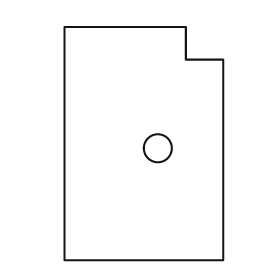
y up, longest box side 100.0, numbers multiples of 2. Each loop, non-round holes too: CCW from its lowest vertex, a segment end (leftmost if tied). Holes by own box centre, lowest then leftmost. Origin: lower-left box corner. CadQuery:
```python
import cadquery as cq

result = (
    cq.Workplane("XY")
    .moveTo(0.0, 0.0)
    .lineTo(68.0, 0.0)
    .lineTo(68.0, 86.0)
    .lineTo(52.0, 86.0)
    .lineTo(52.0, 100.0)
    .lineTo(0.0, 100.0)
    .close()
    .moveTo(40.0, 48.0)
    .circle(6.0)
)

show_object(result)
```